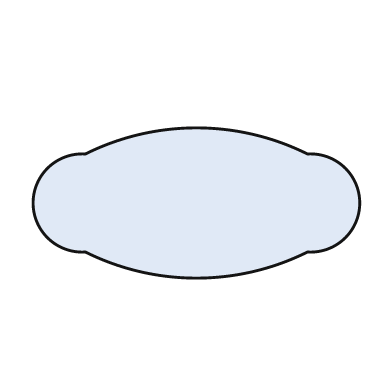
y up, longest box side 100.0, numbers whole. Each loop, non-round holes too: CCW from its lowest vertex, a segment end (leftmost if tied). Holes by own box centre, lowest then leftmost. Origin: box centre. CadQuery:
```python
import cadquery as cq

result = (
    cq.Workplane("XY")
    .moveTo(-34.0, -15.0)
    .threePointArc((0.0, -23.0), (34.0, -15.0))
    .threePointArc((50.0, 0.0), (34.0, 15.0))
    .threePointArc((0.0, 23.0), (-34.0, 15.0))
    .threePointArc((-50.0, 0.0), (-34.0, -15.0))
    .close()
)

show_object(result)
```